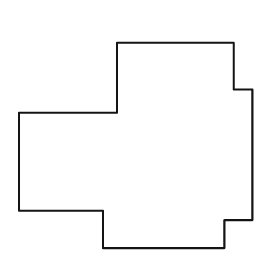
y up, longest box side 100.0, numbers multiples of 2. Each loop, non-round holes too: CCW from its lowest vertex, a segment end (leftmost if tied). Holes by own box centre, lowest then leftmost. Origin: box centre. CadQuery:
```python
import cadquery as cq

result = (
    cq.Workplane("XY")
    .moveTo(-14.0, -44.0)
    .lineTo(38.0, -44.0)
    .lineTo(38.0, -32.0)
    .lineTo(50.0, -32.0)
    .lineTo(50.0, 24.0)
    .lineTo(42.0, 24.0)
    .lineTo(42.0, 44.0)
    .lineTo(-8.0, 44.0)
    .lineTo(-8.0, 14.0)
    .lineTo(-50.0, 14.0)
    .lineTo(-50.0, -28.0)
    .lineTo(-14.0, -28.0)
    .close()
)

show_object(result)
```